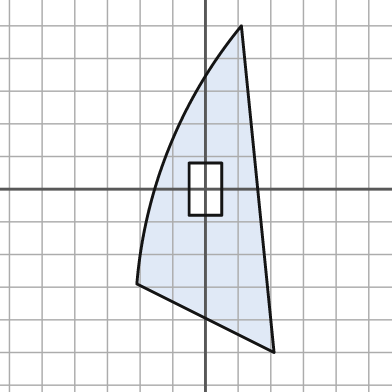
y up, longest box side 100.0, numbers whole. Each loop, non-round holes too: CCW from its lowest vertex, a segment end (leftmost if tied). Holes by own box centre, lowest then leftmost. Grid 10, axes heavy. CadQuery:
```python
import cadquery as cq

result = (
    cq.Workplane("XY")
    .moveTo(21.0, -50.0)
    .lineTo(11.0, 50.0)
    .threePointArc((-11.0, 13.0), (-21.0, -29.0))
    .close()
    .moveTo(-5.0, -8.0)
    .lineTo(5.0, -8.0)
    .lineTo(5.0, 8.0)
    .lineTo(-5.0, 8.0)
    .close()
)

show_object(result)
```